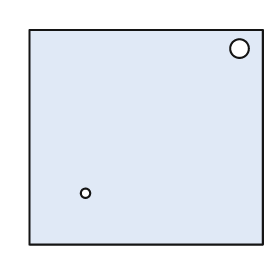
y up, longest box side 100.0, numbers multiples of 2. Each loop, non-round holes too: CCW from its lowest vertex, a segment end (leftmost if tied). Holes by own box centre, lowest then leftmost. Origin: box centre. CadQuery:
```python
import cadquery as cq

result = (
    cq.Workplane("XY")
    .moveTo(-50.0, -46.0)
    .lineTo(50.0, -46.0)
    .lineTo(50.0, 46.0)
    .lineTo(-50.0, 46.0)
    .close()
    .moveTo(-26.0, -24.0)
    .circle(2.0)
    .moveTo(40.0, 38.0)
    .circle(4.0)
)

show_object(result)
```